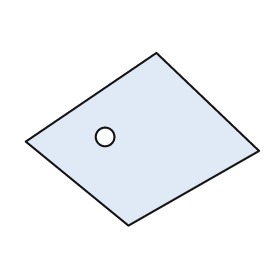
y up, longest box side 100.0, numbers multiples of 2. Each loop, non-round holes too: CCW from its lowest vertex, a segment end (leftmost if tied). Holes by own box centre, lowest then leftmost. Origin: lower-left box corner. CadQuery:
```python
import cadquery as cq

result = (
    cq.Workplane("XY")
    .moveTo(44.0, 0.0)
    .lineTo(100.0, 32.0)
    .lineTo(56.0, 74.0)
    .lineTo(0.0, 36.0)
    .close()
    .moveTo(34.0, 38.0)
    .circle(4.0)
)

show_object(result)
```